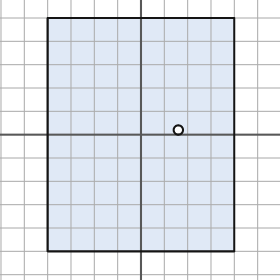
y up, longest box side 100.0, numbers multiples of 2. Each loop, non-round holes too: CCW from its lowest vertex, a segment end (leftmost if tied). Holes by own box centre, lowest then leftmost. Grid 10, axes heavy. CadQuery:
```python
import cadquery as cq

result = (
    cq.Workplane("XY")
    .moveTo(-40.0, -50.0)
    .lineTo(40.0, -50.0)
    .lineTo(40.0, 50.0)
    .lineTo(-40.0, 50.0)
    .close()
    .moveTo(16.0, 2.0)
    .circle(2.0)
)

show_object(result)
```